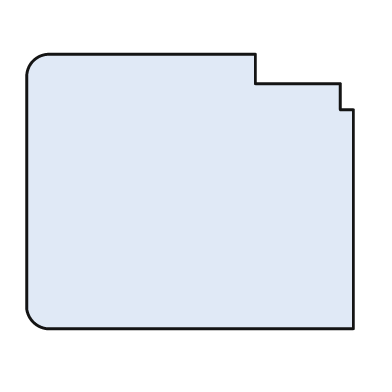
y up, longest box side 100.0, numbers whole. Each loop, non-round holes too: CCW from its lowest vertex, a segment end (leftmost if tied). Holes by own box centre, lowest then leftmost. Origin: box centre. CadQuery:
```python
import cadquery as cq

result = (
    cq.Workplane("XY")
    .moveTo(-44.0, -42.0)
    .lineTo(50.0, -42.0)
    .lineTo(50.0, 25.0)
    .lineTo(46.0, 25.0)
    .lineTo(46.0, 33.0)
    .lineTo(20.0, 33.0)
    .lineTo(20.0, 42.0)
    .lineTo(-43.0, 42.0)
    .threePointArc((-48.0, 40.0), (-50.0, 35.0))
    .lineTo(-50.0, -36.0)
    .threePointArc((-48.0, -40.0), (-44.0, -42.0))
    .close()
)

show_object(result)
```